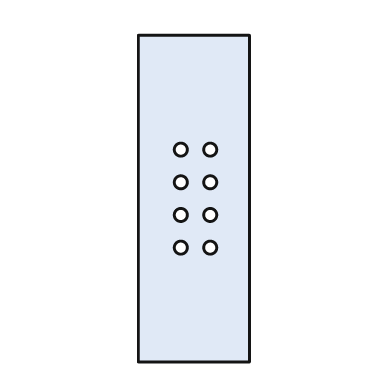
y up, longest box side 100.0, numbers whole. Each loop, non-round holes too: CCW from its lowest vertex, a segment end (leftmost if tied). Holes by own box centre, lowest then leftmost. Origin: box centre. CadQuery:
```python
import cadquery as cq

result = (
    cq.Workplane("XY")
    .moveTo(-17.0, -50.0)
    .lineTo(17.0, -50.0)
    .lineTo(17.0, 50.0)
    .lineTo(-17.0, 50.0)
    .close()
    .moveTo(-4.0, -15.0)
    .circle(2.0)
    .moveTo(5.0, -15.0)
    .circle(2.0)
    .moveTo(-4.0, -5.0)
    .circle(2.0)
    .moveTo(5.0, -5.0)
    .circle(2.0)
    .moveTo(-4.0, 5.0)
    .circle(2.0)
    .moveTo(5.0, 5.0)
    .circle(2.0)
    .moveTo(-4.0, 15.0)
    .circle(2.0)
    .moveTo(5.0, 15.0)
    .circle(2.0)
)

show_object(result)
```